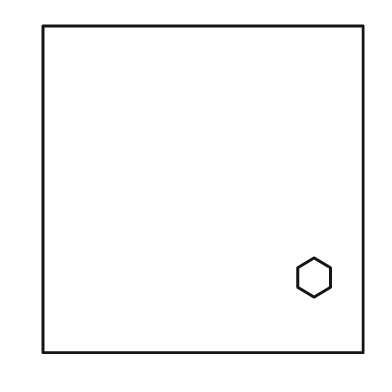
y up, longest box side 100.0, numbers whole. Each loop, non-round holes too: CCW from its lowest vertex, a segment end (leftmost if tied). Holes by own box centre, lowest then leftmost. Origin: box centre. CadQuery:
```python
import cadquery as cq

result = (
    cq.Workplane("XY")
    .moveTo(-49.0, -50.0)
    .lineTo(49.0, -50.0)
    .lineTo(49.0, 50.0)
    .lineTo(-49.0, 50.0)
    .close()
    .moveTo(34.0, -33.0)
    .lineTo(39.0, -30.0)
    .lineTo(39.0, -24.0)
    .lineTo(34.0, -21.0)
    .lineTo(29.0, -24.0)
    .lineTo(29.0, -30.0)
    .close()
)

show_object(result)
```